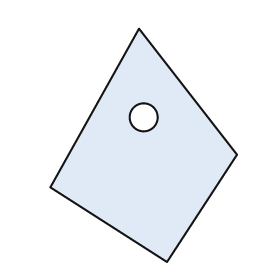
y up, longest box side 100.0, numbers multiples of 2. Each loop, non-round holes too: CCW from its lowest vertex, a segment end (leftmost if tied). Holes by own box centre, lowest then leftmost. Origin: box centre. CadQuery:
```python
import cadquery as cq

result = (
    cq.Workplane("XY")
    .moveTo(10.0, -50.0)
    .lineTo(40.0, -4.0)
    .lineTo(-2.0, 50.0)
    .lineTo(-40.0, -18.0)
    .close()
    .moveTo(0.0, 12.0)
    .circle(6.0)
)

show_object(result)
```